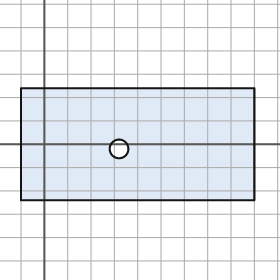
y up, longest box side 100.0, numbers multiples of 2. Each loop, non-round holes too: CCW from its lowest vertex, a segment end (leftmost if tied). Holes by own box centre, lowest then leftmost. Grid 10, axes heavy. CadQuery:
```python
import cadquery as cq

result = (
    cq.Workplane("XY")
    .moveTo(-10.0, -24.0)
    .lineTo(90.0, -24.0)
    .lineTo(90.0, 24.0)
    .lineTo(-10.0, 24.0)
    .close()
    .moveTo(32.0, -2.0)
    .circle(4.0)
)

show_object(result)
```